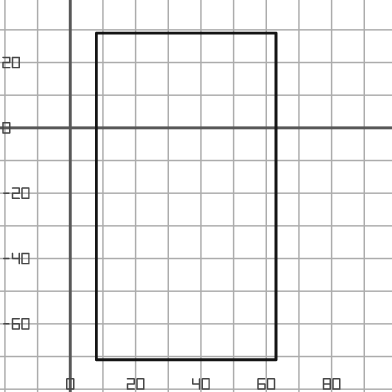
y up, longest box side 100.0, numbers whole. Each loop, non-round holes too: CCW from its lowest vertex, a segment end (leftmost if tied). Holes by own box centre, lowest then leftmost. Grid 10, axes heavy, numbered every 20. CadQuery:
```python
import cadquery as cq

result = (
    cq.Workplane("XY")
    .moveTo(8.0, -71.0)
    .lineTo(63.0, -71.0)
    .lineTo(63.0, 29.0)
    .lineTo(8.0, 29.0)
    .close()
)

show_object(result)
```